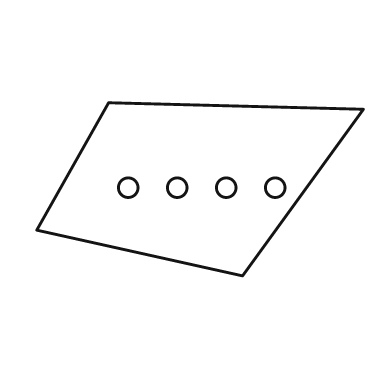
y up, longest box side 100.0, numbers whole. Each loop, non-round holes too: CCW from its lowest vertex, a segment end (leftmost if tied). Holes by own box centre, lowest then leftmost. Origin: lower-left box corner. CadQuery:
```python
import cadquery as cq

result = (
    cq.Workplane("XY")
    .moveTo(63.0, 0.0)
    .lineTo(100.0, 51.0)
    .lineTo(22.0, 53.0)
    .lineTo(0.0, 14.0)
    .close()
    .moveTo(28.0, 27.0)
    .circle(3.0)
    .moveTo(43.0, 27.0)
    .circle(3.0)
    .moveTo(58.0, 27.0)
    .circle(3.0)
    .moveTo(73.0, 27.0)
    .circle(3.0)
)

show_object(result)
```